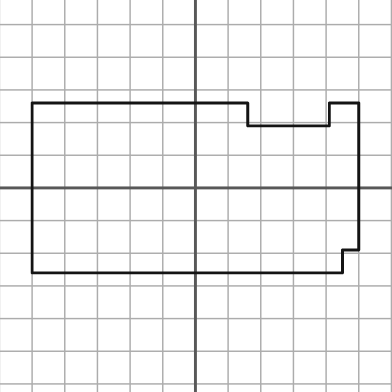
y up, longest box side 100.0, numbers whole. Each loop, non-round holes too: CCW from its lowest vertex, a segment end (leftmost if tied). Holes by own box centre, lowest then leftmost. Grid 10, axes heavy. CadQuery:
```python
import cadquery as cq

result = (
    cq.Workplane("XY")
    .moveTo(-50.0, -26.0)
    .lineTo(45.0, -26.0)
    .lineTo(45.0, -19.0)
    .lineTo(50.0, -19.0)
    .lineTo(50.0, 26.0)
    .lineTo(41.0, 26.0)
    .lineTo(41.0, 19.0)
    .lineTo(16.0, 19.0)
    .lineTo(16.0, 26.0)
    .lineTo(-50.0, 26.0)
    .close()
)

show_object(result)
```